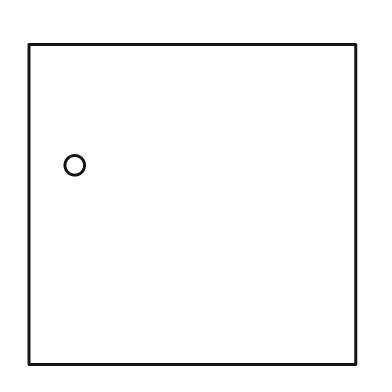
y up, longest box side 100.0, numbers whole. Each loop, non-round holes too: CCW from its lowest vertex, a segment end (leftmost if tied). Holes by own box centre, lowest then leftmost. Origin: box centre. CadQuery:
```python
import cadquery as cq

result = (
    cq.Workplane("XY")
    .moveTo(-50.0, -49.0)
    .lineTo(50.0, -49.0)
    .lineTo(50.0, 49.0)
    .lineTo(-50.0, 49.0)
    .close()
    .moveTo(-36.0, 12.0)
    .circle(3.0)
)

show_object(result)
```